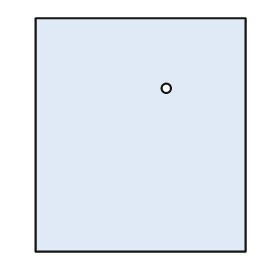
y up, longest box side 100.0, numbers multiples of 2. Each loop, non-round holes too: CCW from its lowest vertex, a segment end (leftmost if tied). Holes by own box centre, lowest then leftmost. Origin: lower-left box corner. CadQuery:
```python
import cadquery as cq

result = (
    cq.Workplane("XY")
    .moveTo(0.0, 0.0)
    .lineTo(90.0, 0.0)
    .lineTo(90.0, 100.0)
    .lineTo(0.0, 100.0)
    .close()
    .moveTo(56.0, 70.0)
    .circle(2.0)
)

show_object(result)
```